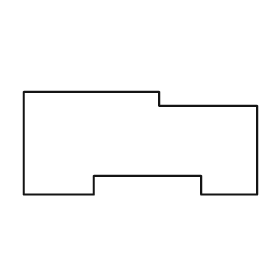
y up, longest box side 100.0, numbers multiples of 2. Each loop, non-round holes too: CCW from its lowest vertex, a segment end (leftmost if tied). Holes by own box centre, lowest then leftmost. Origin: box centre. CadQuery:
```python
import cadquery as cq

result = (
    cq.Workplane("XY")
    .moveTo(-50.0, -22.0)
    .lineTo(-20.0, -22.0)
    .lineTo(-20.0, -14.0)
    .lineTo(26.0, -14.0)
    .lineTo(26.0, -22.0)
    .lineTo(50.0, -22.0)
    .lineTo(50.0, 16.0)
    .lineTo(8.0, 16.0)
    .lineTo(8.0, 22.0)
    .lineTo(-50.0, 22.0)
    .close()
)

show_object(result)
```